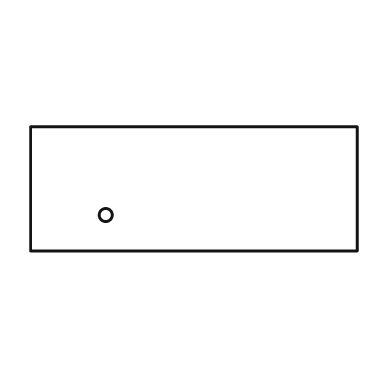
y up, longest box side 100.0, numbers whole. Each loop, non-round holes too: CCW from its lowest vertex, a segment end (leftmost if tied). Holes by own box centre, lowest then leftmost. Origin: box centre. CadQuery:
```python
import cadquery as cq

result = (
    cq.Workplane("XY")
    .moveTo(-50.0, -19.0)
    .lineTo(50.0, -19.0)
    .lineTo(50.0, 19.0)
    .lineTo(-50.0, 19.0)
    .close()
    .moveTo(-27.0, -8.0)
    .circle(2.0)
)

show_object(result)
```